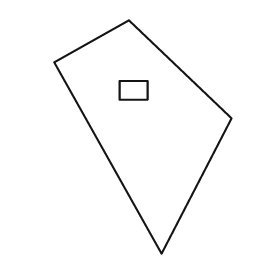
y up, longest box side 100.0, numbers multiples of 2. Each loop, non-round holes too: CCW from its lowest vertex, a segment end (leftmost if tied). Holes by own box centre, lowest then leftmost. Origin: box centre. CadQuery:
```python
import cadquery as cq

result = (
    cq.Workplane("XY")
    .moveTo(8.0, -50.0)
    .lineTo(38.0, 8.0)
    .lineTo(-6.0, 50.0)
    .lineTo(-38.0, 32.0)
    .close()
    .moveTo(-10.0, 16.0)
    .lineTo(2.0, 16.0)
    .lineTo(2.0, 24.0)
    .lineTo(-10.0, 24.0)
    .close()
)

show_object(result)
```